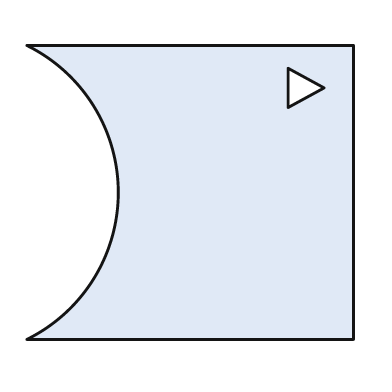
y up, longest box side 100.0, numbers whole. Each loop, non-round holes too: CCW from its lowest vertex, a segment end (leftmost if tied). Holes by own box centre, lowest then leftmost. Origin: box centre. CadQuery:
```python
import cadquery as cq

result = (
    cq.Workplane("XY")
    .moveTo(-50.0, -45.0)
    .lineTo(50.0, -45.0)
    .lineTo(50.0, 45.0)
    .lineTo(-50.0, 45.0)
    .threePointArc((-22.0, 0.0), (-50.0, -45.0))
    .close()
    .moveTo(30.0, 26.0)
    .lineTo(41.0, 32.0)
    .lineTo(30.0, 38.0)
    .close()
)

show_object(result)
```